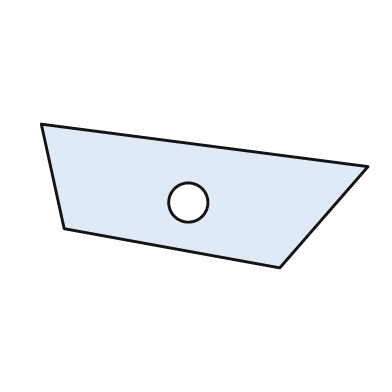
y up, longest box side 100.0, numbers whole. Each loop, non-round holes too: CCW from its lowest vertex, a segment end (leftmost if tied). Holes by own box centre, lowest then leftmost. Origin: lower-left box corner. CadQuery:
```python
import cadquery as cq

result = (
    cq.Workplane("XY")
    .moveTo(73.0, 0.0)
    .lineTo(100.0, 31.0)
    .lineTo(0.0, 44.0)
    .lineTo(7.0, 12.0)
    .close()
    .moveTo(45.0, 20.0)
    .circle(6.0)
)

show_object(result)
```